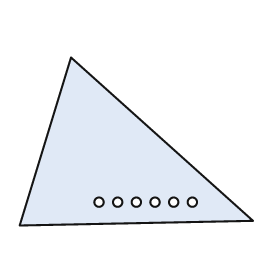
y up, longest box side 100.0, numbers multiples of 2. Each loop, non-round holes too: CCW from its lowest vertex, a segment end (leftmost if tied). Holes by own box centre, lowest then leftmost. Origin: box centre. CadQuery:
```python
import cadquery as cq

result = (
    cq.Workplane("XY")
    .moveTo(-50.0, -36.0)
    .lineTo(50.0, -34.0)
    .lineTo(-28.0, 36.0)
    .close()
    .moveTo(-16.0, -26.0)
    .circle(2.0)
    .moveTo(-8.0, -26.0)
    .circle(2.0)
    .moveTo(0.0, -26.0)
    .circle(2.0)
    .moveTo(8.0, -26.0)
    .circle(2.0)
    .moveTo(16.0, -26.0)
    .circle(2.0)
    .moveTo(24.0, -26.0)
    .circle(2.0)
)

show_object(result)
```